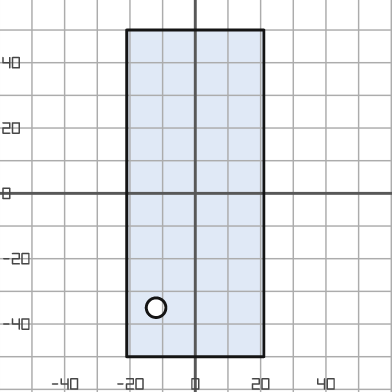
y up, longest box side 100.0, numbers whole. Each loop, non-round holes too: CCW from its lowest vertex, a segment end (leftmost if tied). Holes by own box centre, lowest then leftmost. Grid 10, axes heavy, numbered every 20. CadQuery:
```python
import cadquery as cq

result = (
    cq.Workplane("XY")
    .moveTo(-21.0, -50.0)
    .lineTo(21.0, -50.0)
    .lineTo(21.0, 50.0)
    .lineTo(-21.0, 50.0)
    .close()
    .moveTo(-12.0, -35.0)
    .circle(3.0)
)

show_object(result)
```